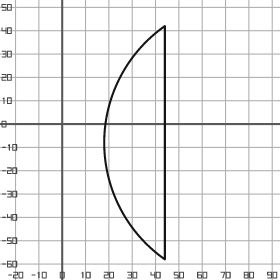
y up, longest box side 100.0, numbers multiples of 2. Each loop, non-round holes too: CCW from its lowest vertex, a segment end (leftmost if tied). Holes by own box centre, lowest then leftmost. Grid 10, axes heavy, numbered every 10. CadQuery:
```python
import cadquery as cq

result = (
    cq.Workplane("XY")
    .moveTo(44.0, -58.0)
    .lineTo(44.0, 42.0)
    .threePointArc((18.0, -8.0), (44.0, -58.0))
    .close()
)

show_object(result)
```